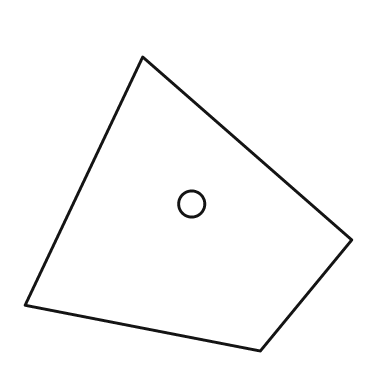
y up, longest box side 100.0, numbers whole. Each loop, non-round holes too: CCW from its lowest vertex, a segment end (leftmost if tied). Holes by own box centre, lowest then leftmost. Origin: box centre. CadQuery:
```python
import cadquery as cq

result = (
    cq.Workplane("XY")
    .moveTo(22.0, -45.0)
    .lineTo(50.0, -11.0)
    .lineTo(-14.0, 45.0)
    .lineTo(-50.0, -31.0)
    .close()
    .moveTo(1.0, 0.0)
    .circle(4.0)
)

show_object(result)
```